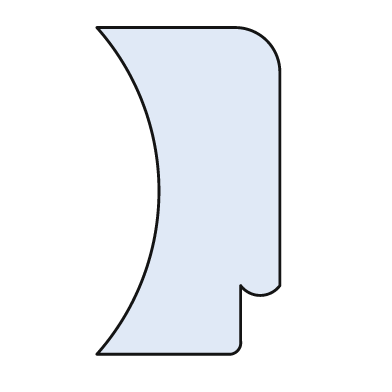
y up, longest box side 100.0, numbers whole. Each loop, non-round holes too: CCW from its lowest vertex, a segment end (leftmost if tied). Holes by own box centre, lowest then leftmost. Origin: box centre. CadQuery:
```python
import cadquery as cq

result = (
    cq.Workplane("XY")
    .moveTo(-28.0, -50.0)
    .lineTo(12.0, -50.0)
    .threePointArc((15.0, -49.0), (16.0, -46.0))
    .lineTo(16.0, -29.0)
    .threePointArc((22.0, -32.0), (28.0, -29.0))
    .lineTo(28.0, 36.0)
    .threePointArc((24.0, 46.0), (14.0, 50.0))
    .lineTo(-28.0, 50.0)
    .threePointArc((-9.0, 0.0), (-28.0, -50.0))
    .close()
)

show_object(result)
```